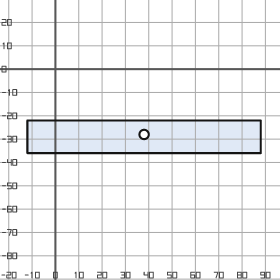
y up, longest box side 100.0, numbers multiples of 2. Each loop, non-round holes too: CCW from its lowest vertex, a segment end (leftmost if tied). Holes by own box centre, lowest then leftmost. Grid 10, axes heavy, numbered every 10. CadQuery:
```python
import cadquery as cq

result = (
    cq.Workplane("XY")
    .moveTo(-12.0, -36.0)
    .lineTo(88.0, -36.0)
    .lineTo(88.0, -22.0)
    .lineTo(-12.0, -22.0)
    .close()
    .moveTo(38.0, -28.0)
    .circle(2.0)
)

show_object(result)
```